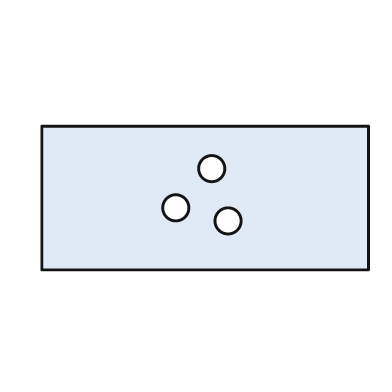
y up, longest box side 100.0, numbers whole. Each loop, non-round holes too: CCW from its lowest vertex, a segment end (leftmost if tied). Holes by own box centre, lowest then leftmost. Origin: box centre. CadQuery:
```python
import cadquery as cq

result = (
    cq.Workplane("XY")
    .moveTo(-50.0, -22.0)
    .lineTo(50.0, -22.0)
    .lineTo(50.0, 22.0)
    .lineTo(-50.0, 22.0)
    .close()
    .moveTo(7.0, -7.0)
    .circle(4.0)
    .moveTo(-9.0, -3.0)
    .circle(4.0)
    .moveTo(2.0, 9.0)
    .circle(4.0)
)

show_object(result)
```